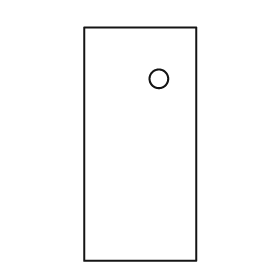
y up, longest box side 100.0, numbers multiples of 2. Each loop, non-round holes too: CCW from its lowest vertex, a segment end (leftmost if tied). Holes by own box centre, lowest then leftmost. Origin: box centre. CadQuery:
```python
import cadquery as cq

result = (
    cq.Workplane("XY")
    .moveTo(-24.0, -50.0)
    .lineTo(24.0, -50.0)
    .lineTo(24.0, 50.0)
    .lineTo(-24.0, 50.0)
    .close()
    .moveTo(8.0, 28.0)
    .circle(4.0)
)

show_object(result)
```